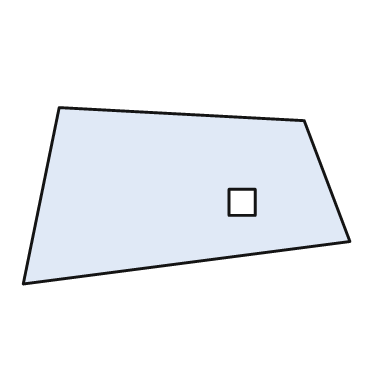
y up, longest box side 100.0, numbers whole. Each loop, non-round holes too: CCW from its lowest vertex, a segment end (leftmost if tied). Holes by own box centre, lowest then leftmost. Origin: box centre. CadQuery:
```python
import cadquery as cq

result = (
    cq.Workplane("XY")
    .moveTo(-50.0, -27.0)
    .lineTo(50.0, -14.0)
    .lineTo(36.0, 23.0)
    .lineTo(-39.0, 27.0)
    .close()
    .moveTo(13.0, -6.0)
    .lineTo(21.0, -6.0)
    .lineTo(21.0, 2.0)
    .lineTo(13.0, 2.0)
    .close()
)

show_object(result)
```